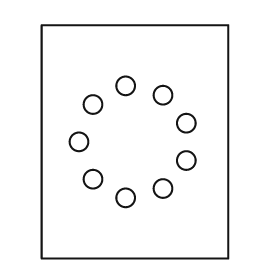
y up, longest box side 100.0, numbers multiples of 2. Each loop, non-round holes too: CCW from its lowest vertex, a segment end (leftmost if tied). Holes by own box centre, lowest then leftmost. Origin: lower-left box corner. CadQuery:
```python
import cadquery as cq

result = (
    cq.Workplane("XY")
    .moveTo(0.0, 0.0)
    .lineTo(80.0, 0.0)
    .lineTo(80.0, 100.0)
    .lineTo(0.0, 100.0)
    .close()
    .moveTo(36.0, 26.0)
    .circle(4.0)
    .moveTo(52.0, 30.0)
    .circle(4.0)
    .moveTo(22.0, 34.0)
    .circle(4.0)
    .moveTo(62.0, 42.0)
    .circle(4.0)
    .moveTo(16.0, 50.0)
    .circle(4.0)
    .moveTo(62.0, 58.0)
    .circle(4.0)
    .moveTo(22.0, 66.0)
    .circle(4.0)
    .moveTo(52.0, 70.0)
    .circle(4.0)
    .moveTo(36.0, 74.0)
    .circle(4.0)
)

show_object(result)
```